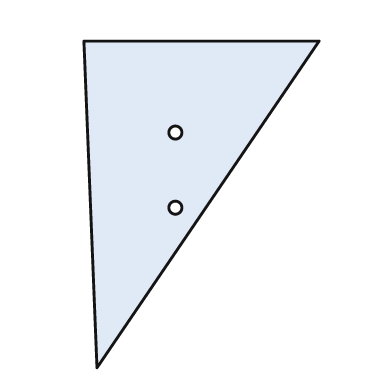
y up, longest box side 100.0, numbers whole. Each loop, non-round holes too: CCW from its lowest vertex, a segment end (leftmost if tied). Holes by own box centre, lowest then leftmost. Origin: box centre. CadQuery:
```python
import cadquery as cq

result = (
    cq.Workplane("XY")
    .moveTo(-32.0, -50.0)
    .lineTo(36.0, 50.0)
    .lineTo(-36.0, 50.0)
    .close()
    .moveTo(-8.0, -1.0)
    .circle(2.0)
    .moveTo(-8.0, 22.0)
    .circle(2.0)
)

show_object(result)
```